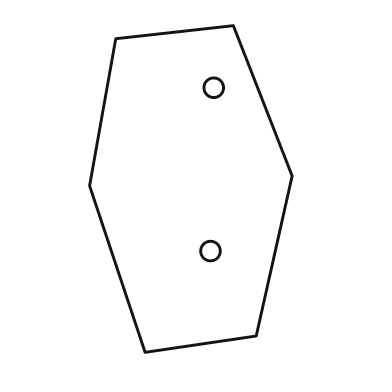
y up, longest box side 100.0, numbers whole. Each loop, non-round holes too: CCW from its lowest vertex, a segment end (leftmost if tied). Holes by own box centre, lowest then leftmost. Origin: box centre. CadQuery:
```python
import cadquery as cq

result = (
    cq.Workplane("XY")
    .moveTo(-14.0, -50.0)
    .lineTo(20.0, -45.0)
    .lineTo(31.0, 4.0)
    .lineTo(13.0, 50.0)
    .lineTo(-23.0, 46.0)
    .lineTo(-31.0, 1.0)
    .close()
    .moveTo(6.0, -19.0)
    .circle(3.0)
    .moveTo(7.0, 31.0)
    .circle(3.0)
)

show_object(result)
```